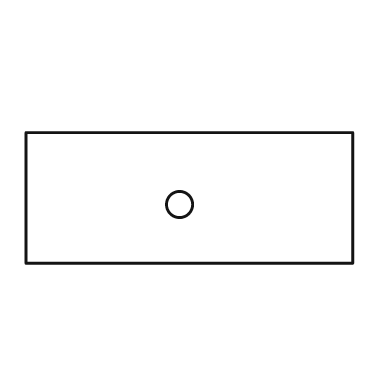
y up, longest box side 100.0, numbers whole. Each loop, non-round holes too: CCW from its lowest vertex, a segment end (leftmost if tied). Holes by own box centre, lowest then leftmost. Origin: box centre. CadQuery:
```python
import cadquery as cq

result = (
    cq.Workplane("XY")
    .moveTo(-50.0, -20.0)
    .lineTo(50.0, -20.0)
    .lineTo(50.0, 20.0)
    .lineTo(-50.0, 20.0)
    .close()
    .moveTo(-3.0, -2.0)
    .circle(4.0)
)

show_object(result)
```